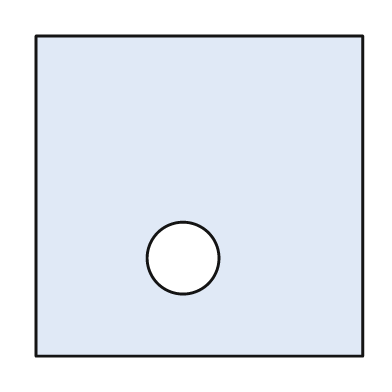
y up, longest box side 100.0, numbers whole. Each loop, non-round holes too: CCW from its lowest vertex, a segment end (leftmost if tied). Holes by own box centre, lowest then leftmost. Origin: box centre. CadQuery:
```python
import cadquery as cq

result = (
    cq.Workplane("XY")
    .moveTo(-50.0, -49.0)
    .lineTo(50.0, -49.0)
    .lineTo(50.0, 49.0)
    .lineTo(-50.0, 49.0)
    .close()
    .moveTo(-5.0, -19.0)
    .circle(11.0)
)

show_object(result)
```